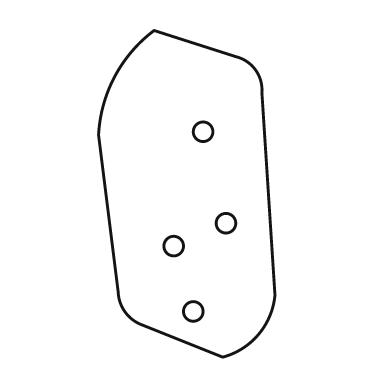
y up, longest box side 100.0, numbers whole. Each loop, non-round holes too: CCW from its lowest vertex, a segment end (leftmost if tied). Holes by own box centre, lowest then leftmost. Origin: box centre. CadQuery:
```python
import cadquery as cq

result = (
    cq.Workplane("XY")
    .moveTo(11.0, -50.0)
    .threePointArc((22.0, -43.0), (27.0, -31.0))
    .lineTo(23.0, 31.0)
    .threePointArc((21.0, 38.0), (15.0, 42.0))
    .lineTo(-10.0, 50.0)
    .threePointArc((-22.0, 36.0), (-27.0, 18.0))
    .lineTo(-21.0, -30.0)
    .threePointArc((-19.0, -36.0), (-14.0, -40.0))
    .close()
    .moveTo(2.0, -36.0)
    .circle(3.0)
    .moveTo(-4.0, -16.0)
    .circle(3.0)
    .moveTo(12.0, -9.0)
    .circle(3.0)
    .moveTo(5.0, 19.0)
    .circle(3.0)
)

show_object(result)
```